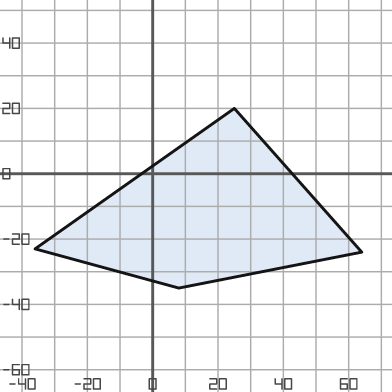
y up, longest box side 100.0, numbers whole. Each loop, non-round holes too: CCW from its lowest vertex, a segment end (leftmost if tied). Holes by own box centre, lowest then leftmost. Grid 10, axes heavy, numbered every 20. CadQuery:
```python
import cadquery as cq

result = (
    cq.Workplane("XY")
    .moveTo(8.0, -35.0)
    .lineTo(64.0, -24.0)
    .lineTo(25.0, 20.0)
    .lineTo(-36.0, -23.0)
    .close()
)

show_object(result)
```